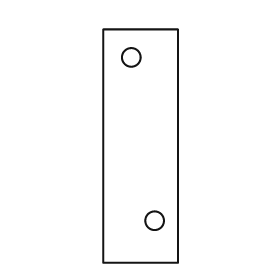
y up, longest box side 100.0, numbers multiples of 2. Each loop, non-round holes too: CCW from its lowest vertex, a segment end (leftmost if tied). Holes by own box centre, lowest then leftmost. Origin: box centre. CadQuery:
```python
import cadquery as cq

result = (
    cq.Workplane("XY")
    .moveTo(-16.0, -50.0)
    .lineTo(16.0, -50.0)
    .lineTo(16.0, 50.0)
    .lineTo(-16.0, 50.0)
    .close()
    .moveTo(6.0, -32.0)
    .circle(4.0)
    .moveTo(-4.0, 38.0)
    .circle(4.0)
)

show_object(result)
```